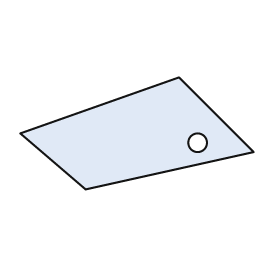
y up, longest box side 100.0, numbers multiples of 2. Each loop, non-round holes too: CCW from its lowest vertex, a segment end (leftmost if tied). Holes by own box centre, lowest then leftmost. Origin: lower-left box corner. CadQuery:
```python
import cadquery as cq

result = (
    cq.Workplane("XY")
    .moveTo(28.0, 0.0)
    .lineTo(100.0, 16.0)
    .lineTo(68.0, 48.0)
    .lineTo(0.0, 24.0)
    .close()
    .moveTo(76.0, 20.0)
    .circle(4.0)
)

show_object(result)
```